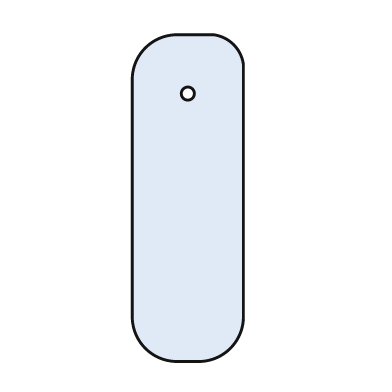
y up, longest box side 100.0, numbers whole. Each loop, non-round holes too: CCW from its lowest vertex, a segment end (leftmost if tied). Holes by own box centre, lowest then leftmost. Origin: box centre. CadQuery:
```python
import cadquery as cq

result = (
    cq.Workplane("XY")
    .moveTo(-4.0, -50.0)
    .lineTo(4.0, -50.0)
    .threePointArc((13.0, -46.0), (17.0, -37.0))
    .lineTo(17.0, 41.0)
    .threePointArc((14.0, 47.0), (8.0, 50.0))
    .lineTo(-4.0, 50.0)
    .threePointArc((-13.0, 46.0), (-17.0, 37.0))
    .lineTo(-17.0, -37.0)
    .threePointArc((-13.0, -46.0), (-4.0, -50.0))
    .close()
    .moveTo(0.0, 32.0)
    .circle(2.0)
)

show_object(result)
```